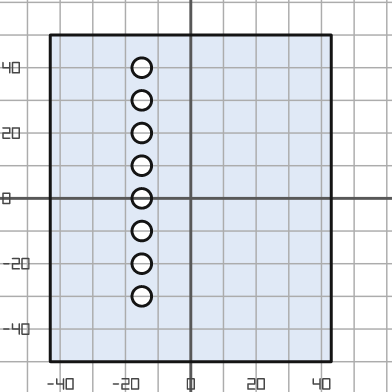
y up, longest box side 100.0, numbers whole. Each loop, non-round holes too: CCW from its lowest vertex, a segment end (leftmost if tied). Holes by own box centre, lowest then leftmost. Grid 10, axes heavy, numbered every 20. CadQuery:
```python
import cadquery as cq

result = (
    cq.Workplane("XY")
    .moveTo(-43.0, -50.0)
    .lineTo(43.0, -50.0)
    .lineTo(43.0, 50.0)
    .lineTo(-43.0, 50.0)
    .close()
    .moveTo(-15.0, -30.0)
    .circle(3.0)
    .moveTo(-15.0, -20.0)
    .circle(3.0)
    .moveTo(-15.0, -10.0)
    .circle(3.0)
    .moveTo(-15.0, 0.0)
    .circle(3.0)
    .moveTo(-15.0, 10.0)
    .circle(3.0)
    .moveTo(-15.0, 20.0)
    .circle(3.0)
    .moveTo(-15.0, 30.0)
    .circle(3.0)
    .moveTo(-15.0, 40.0)
    .circle(3.0)
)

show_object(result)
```